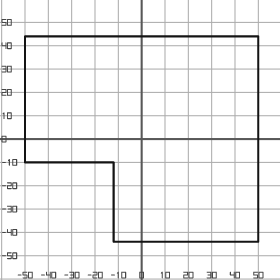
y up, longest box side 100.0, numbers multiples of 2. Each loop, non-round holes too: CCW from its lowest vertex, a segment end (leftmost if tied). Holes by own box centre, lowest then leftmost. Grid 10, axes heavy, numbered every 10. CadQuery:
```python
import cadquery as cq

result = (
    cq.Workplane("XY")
    .moveTo(-12.0, -44.0)
    .lineTo(50.0, -44.0)
    .lineTo(50.0, 44.0)
    .lineTo(-50.0, 44.0)
    .lineTo(-50.0, -10.0)
    .lineTo(-12.0, -10.0)
    .close()
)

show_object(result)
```